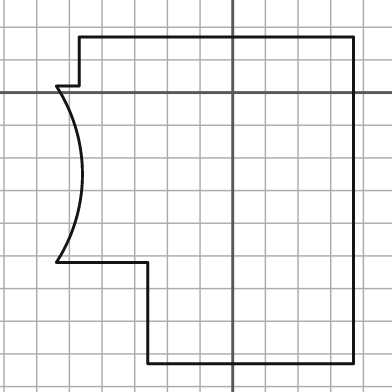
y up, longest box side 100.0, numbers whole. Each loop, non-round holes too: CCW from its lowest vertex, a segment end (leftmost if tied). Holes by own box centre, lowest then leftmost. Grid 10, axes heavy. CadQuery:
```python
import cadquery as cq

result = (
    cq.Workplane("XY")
    .moveTo(-26.0, -83.0)
    .lineTo(37.0, -83.0)
    .lineTo(37.0, 17.0)
    .lineTo(-47.0, 17.0)
    .lineTo(-47.0, 2.0)
    .lineTo(-54.0, 2.0)
    .threePointArc((-46.0, -25.0), (-54.0, -52.0))
    .lineTo(-26.0, -52.0)
    .close()
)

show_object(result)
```